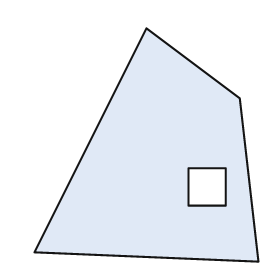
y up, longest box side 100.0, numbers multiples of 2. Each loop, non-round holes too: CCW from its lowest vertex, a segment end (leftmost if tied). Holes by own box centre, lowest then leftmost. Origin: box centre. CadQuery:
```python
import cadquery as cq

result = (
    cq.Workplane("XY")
    .moveTo(48.0, -50.0)
    .lineTo(40.0, 20.0)
    .lineTo(0.0, 50.0)
    .lineTo(-48.0, -46.0)
    .close()
    .moveTo(18.0, -26.0)
    .lineTo(34.0, -26.0)
    .lineTo(34.0, -10.0)
    .lineTo(18.0, -10.0)
    .close()
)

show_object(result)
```